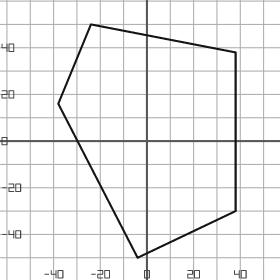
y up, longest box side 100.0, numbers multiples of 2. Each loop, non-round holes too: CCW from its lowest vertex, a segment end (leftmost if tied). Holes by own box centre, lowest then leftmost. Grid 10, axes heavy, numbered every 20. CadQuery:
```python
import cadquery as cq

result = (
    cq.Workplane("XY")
    .moveTo(-4.0, -50.0)
    .lineTo(38.0, -30.0)
    .lineTo(38.0, 38.0)
    .lineTo(-24.0, 50.0)
    .lineTo(-38.0, 16.0)
    .close()
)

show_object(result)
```